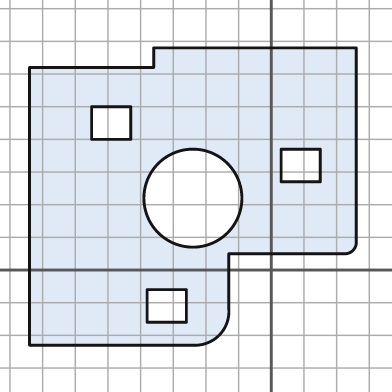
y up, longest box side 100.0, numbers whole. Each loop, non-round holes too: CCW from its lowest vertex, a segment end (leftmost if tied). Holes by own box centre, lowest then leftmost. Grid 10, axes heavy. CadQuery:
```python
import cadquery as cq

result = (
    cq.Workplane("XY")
    .moveTo(-74.0, -23.0)
    .lineTo(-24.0, -23.0)
    .threePointArc((-16.0, -20.0), (-13.0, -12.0))
    .lineTo(-13.0, 5.0)
    .lineTo(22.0, 5.0)
    .threePointArc((25.0, 6.0), (26.0, 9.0))
    .lineTo(26.0, 68.0)
    .lineTo(-36.0, 68.0)
    .lineTo(-36.0, 62.0)
    .lineTo(-74.0, 62.0)
    .close()
    .moveTo(-38.0, -16.0)
    .lineTo(-26.0, -16.0)
    .lineTo(-26.0, -6.0)
    .lineTo(-38.0, -6.0)
    .close()
    .moveTo(-24.0, 22.0)
    .circle(15.0)
    .moveTo(3.0, 27.0)
    .lineTo(15.0, 27.0)
    .lineTo(15.0, 37.0)
    .lineTo(3.0, 37.0)
    .close()
    .moveTo(-55.0, 40.0)
    .lineTo(-43.0, 40.0)
    .lineTo(-43.0, 50.0)
    .lineTo(-55.0, 50.0)
    .close()
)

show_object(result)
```